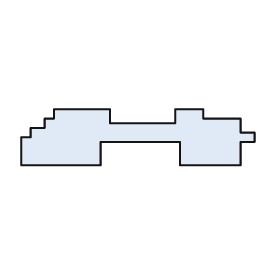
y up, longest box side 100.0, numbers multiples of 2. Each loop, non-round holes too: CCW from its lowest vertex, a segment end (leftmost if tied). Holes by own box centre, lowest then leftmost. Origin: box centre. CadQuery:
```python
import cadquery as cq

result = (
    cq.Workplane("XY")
    .moveTo(-50.0, -12.0)
    .lineTo(-16.0, -12.0)
    .lineTo(-16.0, -2.0)
    .lineTo(18.0, -2.0)
    .lineTo(18.0, -12.0)
    .lineTo(44.0, -12.0)
    .lineTo(44.0, -2.0)
    .lineTo(50.0, -2.0)
    .lineTo(50.0, 2.0)
    .lineTo(44.0, 2.0)
    .lineTo(44.0, 8.0)
    .lineTo(28.0, 8.0)
    .lineTo(28.0, 12.0)
    .lineTo(16.0, 12.0)
    .lineTo(16.0, 6.0)
    .lineTo(-12.0, 6.0)
    .lineTo(-12.0, 12.0)
    .lineTo(-36.0, 12.0)
    .lineTo(-36.0, 8.0)
    .lineTo(-40.0, 8.0)
    .lineTo(-40.0, 4.0)
    .lineTo(-46.0, 4.0)
    .lineTo(-46.0, 0.0)
    .lineTo(-50.0, 0.0)
    .close()
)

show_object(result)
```